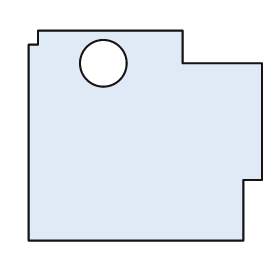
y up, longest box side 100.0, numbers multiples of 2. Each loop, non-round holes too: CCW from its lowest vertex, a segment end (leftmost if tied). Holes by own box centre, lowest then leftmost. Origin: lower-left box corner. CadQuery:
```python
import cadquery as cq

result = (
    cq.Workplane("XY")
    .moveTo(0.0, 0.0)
    .lineTo(92.0, 0.0)
    .lineTo(92.0, 26.0)
    .lineTo(100.0, 26.0)
    .lineTo(100.0, 76.0)
    .lineTo(66.0, 76.0)
    .lineTo(66.0, 90.0)
    .lineTo(4.0, 90.0)
    .lineTo(4.0, 84.0)
    .lineTo(0.0, 84.0)
    .close()
    .moveTo(32.0, 76.0)
    .circle(10.0)
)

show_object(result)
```